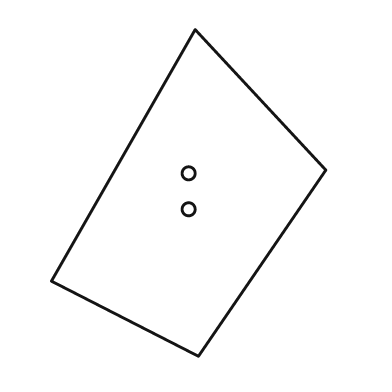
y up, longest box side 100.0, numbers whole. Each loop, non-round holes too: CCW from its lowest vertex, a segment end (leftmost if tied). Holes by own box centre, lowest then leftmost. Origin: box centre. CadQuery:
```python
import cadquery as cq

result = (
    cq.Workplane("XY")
    .moveTo(3.0, -50.0)
    .lineTo(42.0, 7.0)
    .lineTo(2.0, 50.0)
    .lineTo(-42.0, -27.0)
    .close()
    .moveTo(0.0, -5.0)
    .circle(2.0)
    .moveTo(0.0, 6.0)
    .circle(2.0)
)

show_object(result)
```